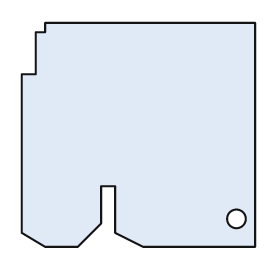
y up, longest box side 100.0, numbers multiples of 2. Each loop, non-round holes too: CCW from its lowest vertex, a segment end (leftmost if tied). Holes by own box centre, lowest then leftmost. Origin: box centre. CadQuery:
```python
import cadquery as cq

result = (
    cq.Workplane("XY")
    .moveTo(-40.0, -48.0)
    .lineTo(-26.0, -48.0)
    .lineTo(-16.0, -38.0)
    .lineTo(-16.0, -22.0)
    .lineTo(-10.0, -22.0)
    .lineTo(-10.0, -42.0)
    .lineTo(2.0, -48.0)
    .lineTo(50.0, -48.0)
    .lineTo(50.0, 48.0)
    .lineTo(-40.0, 48.0)
    .lineTo(-40.0, 44.0)
    .lineTo(-44.0, 44.0)
    .lineTo(-44.0, 26.0)
    .lineTo(-50.0, 26.0)
    .lineTo(-50.0, -42.0)
    .close()
    .moveTo(42.0, -36.0)
    .circle(4.0)
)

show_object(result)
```